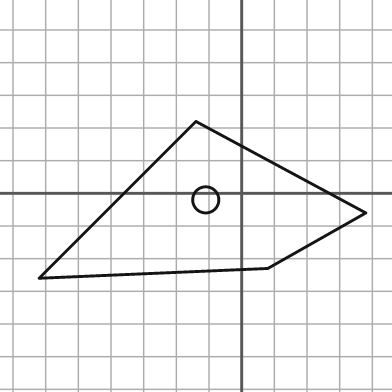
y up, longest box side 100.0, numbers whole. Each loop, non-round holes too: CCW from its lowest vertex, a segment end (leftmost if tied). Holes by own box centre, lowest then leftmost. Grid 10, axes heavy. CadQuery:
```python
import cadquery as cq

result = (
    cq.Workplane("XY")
    .moveTo(-62.0, -26.0)
    .lineTo(8.0, -23.0)
    .lineTo(38.0, -6.0)
    .lineTo(-14.0, 22.0)
    .close()
    .moveTo(-11.0, -2.0)
    .circle(4.0)
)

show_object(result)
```